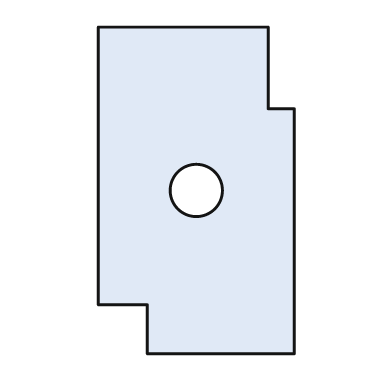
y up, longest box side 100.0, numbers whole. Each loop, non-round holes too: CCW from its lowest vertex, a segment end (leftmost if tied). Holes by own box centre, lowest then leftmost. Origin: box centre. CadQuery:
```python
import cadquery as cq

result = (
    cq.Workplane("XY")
    .moveTo(-15.0, -50.0)
    .lineTo(30.0, -50.0)
    .lineTo(30.0, 25.0)
    .lineTo(22.0, 25.0)
    .lineTo(22.0, 50.0)
    .lineTo(-30.0, 50.0)
    .lineTo(-30.0, -35.0)
    .lineTo(-15.0, -35.0)
    .close()
    .moveTo(0.0, 0.0)
    .circle(8.0)
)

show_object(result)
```